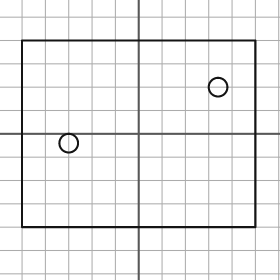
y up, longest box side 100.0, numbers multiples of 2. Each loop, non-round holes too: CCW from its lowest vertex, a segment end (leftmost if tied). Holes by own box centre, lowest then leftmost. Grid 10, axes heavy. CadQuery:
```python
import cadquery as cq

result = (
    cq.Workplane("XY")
    .moveTo(-50.0, -40.0)
    .lineTo(50.0, -40.0)
    .lineTo(50.0, 40.0)
    .lineTo(-50.0, 40.0)
    .close()
    .moveTo(-30.0, -4.0)
    .circle(4.0)
    .moveTo(34.0, 20.0)
    .circle(4.0)
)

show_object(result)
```